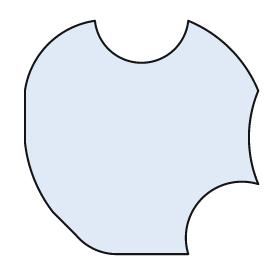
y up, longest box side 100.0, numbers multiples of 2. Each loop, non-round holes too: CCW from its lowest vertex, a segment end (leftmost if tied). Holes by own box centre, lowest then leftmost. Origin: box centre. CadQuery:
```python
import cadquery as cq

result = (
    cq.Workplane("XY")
    .moveTo(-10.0, -50.0)
    .lineTo(20.0, -50.0)
    .threePointArc((26.0, -26.0), (50.0, -20.0))
    .threePointArc((46.0, 0.0), (50.0, 20.0))
    .threePointArc((38.0, 38.0), (20.0, 50.0))
    .threePointArc((0.0, 32.0), (-20.0, 50.0))
    .threePointArc((-40.0, 40.0), (-50.0, 20.0))
    .lineTo(-50.0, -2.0)
    .threePointArc((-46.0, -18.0), (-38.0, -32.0))
    .lineTo(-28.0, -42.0)
    .threePointArc((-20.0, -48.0), (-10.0, -50.0))
    .close()
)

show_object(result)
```